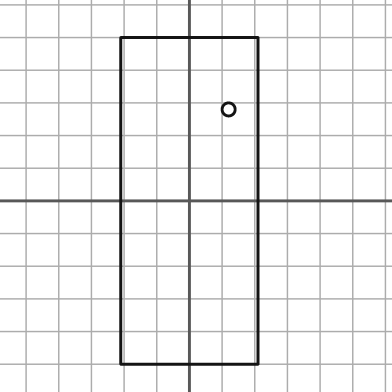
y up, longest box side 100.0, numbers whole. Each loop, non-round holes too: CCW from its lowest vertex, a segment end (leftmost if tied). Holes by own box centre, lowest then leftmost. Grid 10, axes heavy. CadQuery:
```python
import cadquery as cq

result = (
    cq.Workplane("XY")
    .moveTo(-21.0, -50.0)
    .lineTo(21.0, -50.0)
    .lineTo(21.0, 50.0)
    .lineTo(-21.0, 50.0)
    .close()
    .moveTo(12.0, 28.0)
    .circle(2.0)
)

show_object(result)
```